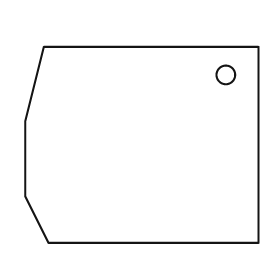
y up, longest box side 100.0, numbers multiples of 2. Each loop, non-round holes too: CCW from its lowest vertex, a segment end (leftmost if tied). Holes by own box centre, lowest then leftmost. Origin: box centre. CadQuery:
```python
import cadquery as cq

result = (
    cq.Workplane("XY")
    .moveTo(-40.0, -42.0)
    .lineTo(50.0, -42.0)
    .lineTo(50.0, 42.0)
    .lineTo(-42.0, 42.0)
    .lineTo(-50.0, 10.0)
    .lineTo(-50.0, -22.0)
    .close()
    .moveTo(36.0, 30.0)
    .circle(4.0)
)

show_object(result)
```